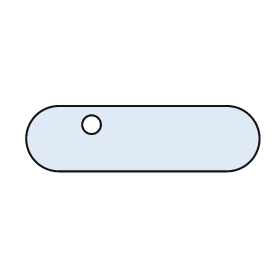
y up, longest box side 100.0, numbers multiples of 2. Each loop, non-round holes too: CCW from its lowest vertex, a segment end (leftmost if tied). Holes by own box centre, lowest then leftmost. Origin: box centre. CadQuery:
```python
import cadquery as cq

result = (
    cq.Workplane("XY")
    .moveTo(-36.0, -14.0)
    .lineTo(36.0, -14.0)
    .threePointArc((50.0, 0.0), (36.0, 14.0))
    .lineTo(-36.0, 14.0)
    .threePointArc((-50.0, 0.0), (-36.0, -14.0))
    .close()
    .moveTo(-22.0, 6.0)
    .circle(4.0)
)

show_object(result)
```